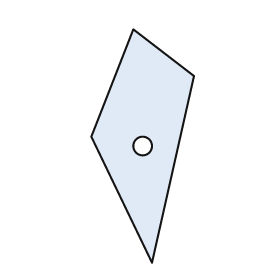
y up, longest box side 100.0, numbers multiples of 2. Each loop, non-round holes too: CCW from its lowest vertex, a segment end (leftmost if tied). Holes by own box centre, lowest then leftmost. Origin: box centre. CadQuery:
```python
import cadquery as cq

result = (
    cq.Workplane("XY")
    .moveTo(4.0, -50.0)
    .lineTo(22.0, 30.0)
    .lineTo(-4.0, 50.0)
    .lineTo(-22.0, 4.0)
    .close()
    .moveTo(0.0, 0.0)
    .circle(4.0)
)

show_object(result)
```